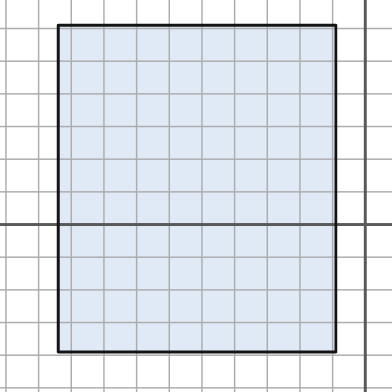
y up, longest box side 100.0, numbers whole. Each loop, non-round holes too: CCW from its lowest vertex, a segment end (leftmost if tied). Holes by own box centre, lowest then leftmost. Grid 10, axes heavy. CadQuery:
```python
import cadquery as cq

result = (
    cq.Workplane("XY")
    .moveTo(-94.0, -39.0)
    .lineTo(-9.0, -39.0)
    .lineTo(-9.0, 61.0)
    .lineTo(-94.0, 61.0)
    .close()
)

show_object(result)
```